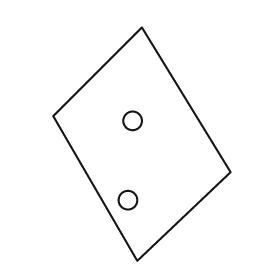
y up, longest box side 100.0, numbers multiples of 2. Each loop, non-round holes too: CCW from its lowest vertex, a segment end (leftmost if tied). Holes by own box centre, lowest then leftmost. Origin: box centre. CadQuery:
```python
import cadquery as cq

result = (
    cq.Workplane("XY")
    .moveTo(-2.0, -50.0)
    .lineTo(38.0, -12.0)
    .lineTo(0.0, 50.0)
    .lineTo(-38.0, 12.0)
    .close()
    .moveTo(-6.0, -24.0)
    .circle(4.0)
    .moveTo(-4.0, 10.0)
    .circle(4.0)
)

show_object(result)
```